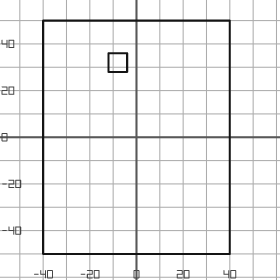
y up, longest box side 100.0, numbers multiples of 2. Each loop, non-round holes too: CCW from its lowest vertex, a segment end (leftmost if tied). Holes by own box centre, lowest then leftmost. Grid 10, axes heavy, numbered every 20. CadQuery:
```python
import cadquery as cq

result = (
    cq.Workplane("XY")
    .moveTo(-40.0, -50.0)
    .lineTo(40.0, -50.0)
    .lineTo(40.0, 50.0)
    .lineTo(-40.0, 50.0)
    .close()
    .moveTo(-12.0, 28.0)
    .lineTo(-4.0, 28.0)
    .lineTo(-4.0, 36.0)
    .lineTo(-12.0, 36.0)
    .close()
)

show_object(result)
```